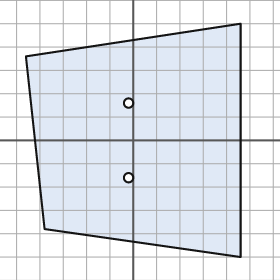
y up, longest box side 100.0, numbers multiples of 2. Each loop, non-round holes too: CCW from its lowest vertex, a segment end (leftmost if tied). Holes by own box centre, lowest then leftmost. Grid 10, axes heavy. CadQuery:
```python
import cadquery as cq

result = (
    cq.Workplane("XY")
    .moveTo(46.0, -50.0)
    .lineTo(46.0, 50.0)
    .lineTo(-46.0, 36.0)
    .lineTo(-38.0, -38.0)
    .close()
    .moveTo(-2.0, -16.0)
    .circle(2.0)
    .moveTo(-2.0, 16.0)
    .circle(2.0)
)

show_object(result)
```